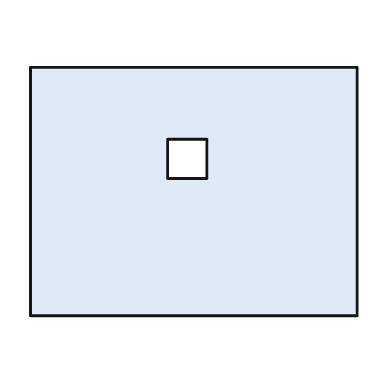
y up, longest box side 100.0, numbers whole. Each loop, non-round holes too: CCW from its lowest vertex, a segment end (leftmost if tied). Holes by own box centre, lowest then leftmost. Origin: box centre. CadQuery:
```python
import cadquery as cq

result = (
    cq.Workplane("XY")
    .moveTo(-50.0, -38.0)
    .lineTo(50.0, -38.0)
    .lineTo(50.0, 38.0)
    .lineTo(-50.0, 38.0)
    .close()
    .moveTo(-8.0, 4.0)
    .lineTo(4.0, 4.0)
    .lineTo(4.0, 16.0)
    .lineTo(-8.0, 16.0)
    .close()
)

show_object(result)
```